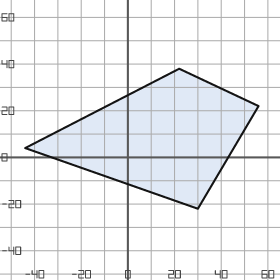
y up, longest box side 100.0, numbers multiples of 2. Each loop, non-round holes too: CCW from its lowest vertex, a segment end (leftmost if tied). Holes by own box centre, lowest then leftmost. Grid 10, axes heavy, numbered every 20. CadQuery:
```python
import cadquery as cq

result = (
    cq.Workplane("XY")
    .moveTo(30.0, -22.0)
    .lineTo(56.0, 22.0)
    .lineTo(22.0, 38.0)
    .lineTo(-44.0, 4.0)
    .close()
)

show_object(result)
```